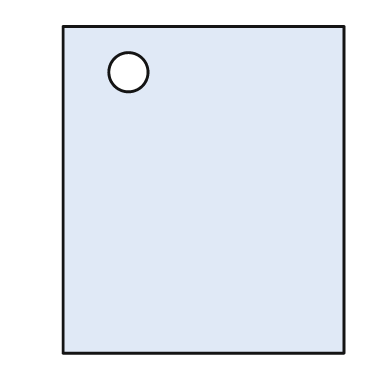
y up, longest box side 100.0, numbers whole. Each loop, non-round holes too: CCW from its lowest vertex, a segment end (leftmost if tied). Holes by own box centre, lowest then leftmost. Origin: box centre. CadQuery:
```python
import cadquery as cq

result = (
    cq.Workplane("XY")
    .moveTo(-43.0, -50.0)
    .lineTo(43.0, -50.0)
    .lineTo(43.0, 50.0)
    .lineTo(-43.0, 50.0)
    .close()
    .moveTo(-23.0, 36.0)
    .circle(6.0)
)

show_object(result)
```